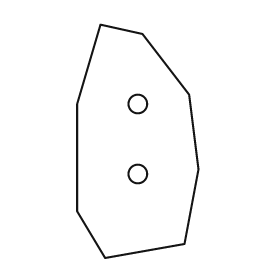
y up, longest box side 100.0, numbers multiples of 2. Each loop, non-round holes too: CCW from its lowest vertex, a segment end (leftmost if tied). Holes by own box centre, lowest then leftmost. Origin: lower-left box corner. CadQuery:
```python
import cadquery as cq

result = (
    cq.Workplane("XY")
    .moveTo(12.0, 0.0)
    .lineTo(46.0, 6.0)
    .lineTo(52.0, 38.0)
    .lineTo(48.0, 70.0)
    .lineTo(28.0, 96.0)
    .lineTo(10.0, 100.0)
    .lineTo(0.0, 66.0)
    .lineTo(0.0, 20.0)
    .close()
    .moveTo(26.0, 36.0)
    .circle(4.0)
    .moveTo(26.0, 66.0)
    .circle(4.0)
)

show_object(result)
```